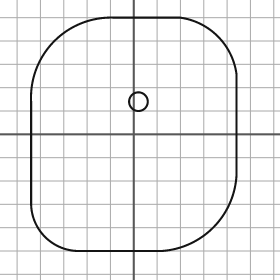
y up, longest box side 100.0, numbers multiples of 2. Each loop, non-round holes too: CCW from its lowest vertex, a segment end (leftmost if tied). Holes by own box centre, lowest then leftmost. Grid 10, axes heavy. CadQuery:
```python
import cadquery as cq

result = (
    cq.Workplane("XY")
    .moveTo(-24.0, -50.0)
    .lineTo(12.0, -50.0)
    .threePointArc((34.0, -40.0), (44.0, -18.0))
    .lineTo(44.0, 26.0)
    .threePointArc((36.0, 42.0), (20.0, 50.0))
    .lineTo(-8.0, 50.0)
    .threePointArc((-34.0, 40.0), (-44.0, 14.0))
    .lineTo(-44.0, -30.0)
    .threePointArc((-38.0, -44.0), (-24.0, -50.0))
    .close()
    .moveTo(2.0, 14.0)
    .circle(4.0)
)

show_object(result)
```